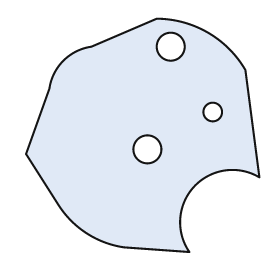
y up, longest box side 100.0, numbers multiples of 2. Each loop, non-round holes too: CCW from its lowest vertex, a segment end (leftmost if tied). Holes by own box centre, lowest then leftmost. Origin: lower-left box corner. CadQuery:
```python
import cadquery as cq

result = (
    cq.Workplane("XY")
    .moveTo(70.0, 0.0)
    .threePointArc((72.0, 28.0), (100.0, 32.0))
    .lineTo(94.0, 78.0)
    .threePointArc((78.0, 94.0), (56.0, 100.0))
    .lineTo(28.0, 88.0)
    .threePointArc((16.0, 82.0), (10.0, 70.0))
    .lineTo(0.0, 42.0)
    .lineTo(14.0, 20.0)
    .threePointArc((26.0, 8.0), (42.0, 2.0))
    .close()
    .moveTo(52.0, 44.0)
    .circle(6.0)
    .moveTo(80.0, 60.0)
    .circle(4.0)
    .moveTo(62.0, 88.0)
    .circle(6.0)
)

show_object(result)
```